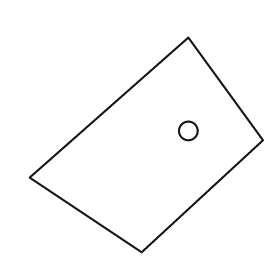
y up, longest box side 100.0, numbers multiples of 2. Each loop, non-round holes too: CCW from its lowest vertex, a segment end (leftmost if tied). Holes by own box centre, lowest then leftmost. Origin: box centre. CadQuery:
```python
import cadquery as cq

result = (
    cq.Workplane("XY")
    .moveTo(-2.0, -46.0)
    .lineTo(50.0, 2.0)
    .lineTo(18.0, 46.0)
    .lineTo(-50.0, -14.0)
    .close()
    .moveTo(18.0, 6.0)
    .circle(4.0)
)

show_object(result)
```